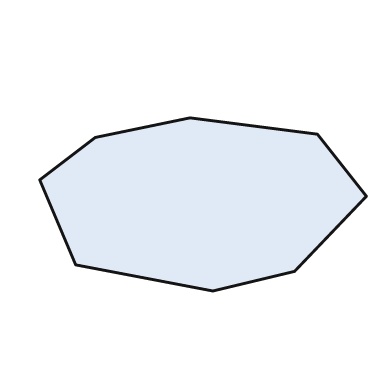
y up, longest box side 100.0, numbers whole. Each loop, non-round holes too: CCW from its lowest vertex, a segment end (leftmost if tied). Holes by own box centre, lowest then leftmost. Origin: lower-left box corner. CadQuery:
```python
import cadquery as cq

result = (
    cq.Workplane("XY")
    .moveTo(53.0, 0.0)
    .lineTo(78.0, 6.0)
    .lineTo(100.0, 29.0)
    .lineTo(85.0, 48.0)
    .lineTo(46.0, 53.0)
    .lineTo(17.0, 47.0)
    .lineTo(0.0, 34.0)
    .lineTo(11.0, 8.0)
    .close()
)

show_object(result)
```